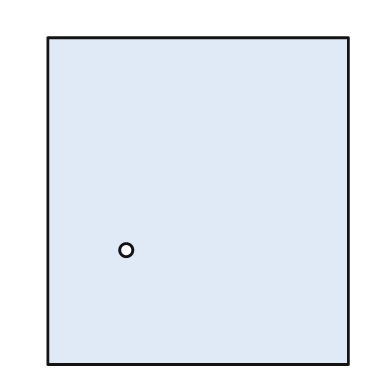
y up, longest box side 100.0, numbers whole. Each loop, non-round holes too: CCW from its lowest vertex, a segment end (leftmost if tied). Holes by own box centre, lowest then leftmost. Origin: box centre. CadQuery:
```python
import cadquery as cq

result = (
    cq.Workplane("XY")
    .moveTo(-46.0, -50.0)
    .lineTo(46.0, -50.0)
    .lineTo(46.0, 50.0)
    .lineTo(-46.0, 50.0)
    .close()
    .moveTo(-22.0, -15.0)
    .circle(2.0)
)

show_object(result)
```